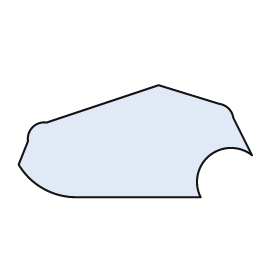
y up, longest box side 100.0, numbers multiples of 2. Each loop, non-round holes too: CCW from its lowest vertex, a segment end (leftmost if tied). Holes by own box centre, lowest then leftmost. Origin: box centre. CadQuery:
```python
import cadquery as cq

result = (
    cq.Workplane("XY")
    .moveTo(-26.0, -24.0)
    .lineTo(28.0, -24.0)
    .threePointArc((32.0, -6.0), (50.0, -6.0))
    .lineTo(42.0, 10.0)
    .threePointArc((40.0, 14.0), (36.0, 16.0))
    .lineTo(10.0, 24.0)
    .lineTo(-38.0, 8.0)
    .threePointArc((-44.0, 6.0), (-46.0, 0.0))
    .lineTo(-50.0, -10.0)
    .threePointArc((-40.0, -20.0), (-26.0, -24.0))
    .close()
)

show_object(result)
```